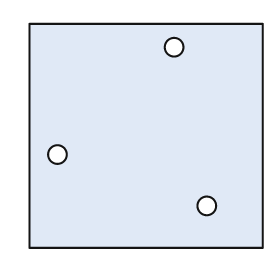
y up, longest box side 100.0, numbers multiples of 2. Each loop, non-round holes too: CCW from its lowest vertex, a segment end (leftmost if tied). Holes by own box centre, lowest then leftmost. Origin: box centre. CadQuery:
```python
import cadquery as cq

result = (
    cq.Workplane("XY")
    .moveTo(-50.0, -48.0)
    .lineTo(50.0, -48.0)
    .lineTo(50.0, 48.0)
    .lineTo(-50.0, 48.0)
    .close()
    .moveTo(26.0, -30.0)
    .circle(4.0)
    .moveTo(-38.0, -8.0)
    .circle(4.0)
    .moveTo(12.0, 38.0)
    .circle(4.0)
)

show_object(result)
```